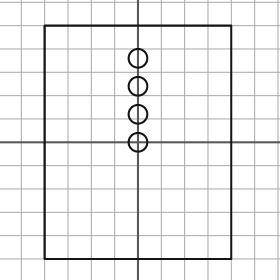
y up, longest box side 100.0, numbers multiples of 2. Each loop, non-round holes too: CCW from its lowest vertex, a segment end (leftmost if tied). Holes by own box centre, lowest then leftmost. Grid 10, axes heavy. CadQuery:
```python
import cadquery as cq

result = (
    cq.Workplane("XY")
    .moveTo(-40.0, -50.0)
    .lineTo(40.0, -50.0)
    .lineTo(40.0, 50.0)
    .lineTo(-40.0, 50.0)
    .close()
    .moveTo(0.0, 0.0)
    .circle(4.0)
    .moveTo(0.0, 12.0)
    .circle(4.0)
    .moveTo(0.0, 24.0)
    .circle(4.0)
    .moveTo(0.0, 36.0)
    .circle(4.0)
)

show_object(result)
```